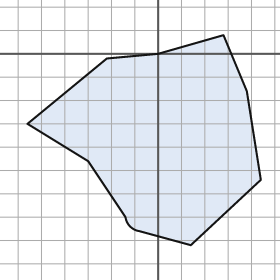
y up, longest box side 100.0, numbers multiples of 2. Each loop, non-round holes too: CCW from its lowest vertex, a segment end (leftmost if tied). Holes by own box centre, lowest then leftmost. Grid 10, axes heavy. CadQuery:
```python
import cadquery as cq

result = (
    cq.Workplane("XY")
    .moveTo(14.0, -82.0)
    .lineTo(44.0, -54.0)
    .lineTo(38.0, -16.0)
    .lineTo(28.0, 8.0)
    .lineTo(0.0, 0.0)
    .lineTo(-22.0, -2.0)
    .lineTo(-56.0, -30.0)
    .lineTo(-30.0, -46.0)
    .lineTo(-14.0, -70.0)
    .threePointArc((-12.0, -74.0), (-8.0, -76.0))
    .close()
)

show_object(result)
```